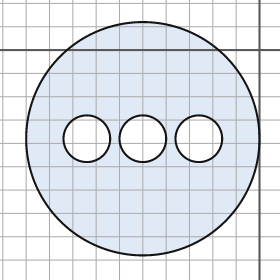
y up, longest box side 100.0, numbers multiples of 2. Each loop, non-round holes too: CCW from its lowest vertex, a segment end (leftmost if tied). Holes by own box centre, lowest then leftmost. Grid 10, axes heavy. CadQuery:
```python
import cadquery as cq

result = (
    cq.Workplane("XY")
    .moveTo(-50.0, -38.0)
    .circle(50.0)
    .moveTo(-74.0, -38.0)
    .circle(10.0)
    .moveTo(-50.0, -38.0)
    .circle(10.0)
    .moveTo(-26.0, -38.0)
    .circle(10.0)
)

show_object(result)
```